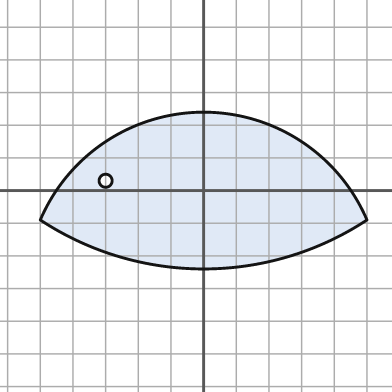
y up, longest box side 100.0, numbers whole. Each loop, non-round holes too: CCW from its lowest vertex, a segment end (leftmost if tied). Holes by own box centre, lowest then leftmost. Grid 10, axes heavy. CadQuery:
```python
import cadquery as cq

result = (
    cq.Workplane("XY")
    .moveTo(-50.0, -9.0)
    .threePointArc((0.0, -24.0), (50.0, -9.0))
    .threePointArc((0.0, 24.0), (-50.0, -9.0))
    .close()
    .moveTo(-30.0, 3.0)
    .circle(2.0)
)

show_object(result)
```